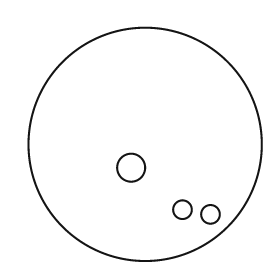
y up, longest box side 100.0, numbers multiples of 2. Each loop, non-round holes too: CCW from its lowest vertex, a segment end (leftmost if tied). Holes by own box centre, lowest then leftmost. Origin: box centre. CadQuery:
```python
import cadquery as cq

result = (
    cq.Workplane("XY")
    .moveTo(0.0, 0.0)
    .circle(50.0)
    .moveTo(28.0, -30.0)
    .circle(4.0)
    .moveTo(16.0, -28.0)
    .circle(4.0)
    .moveTo(-6.0, -10.0)
    .circle(6.0)
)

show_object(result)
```